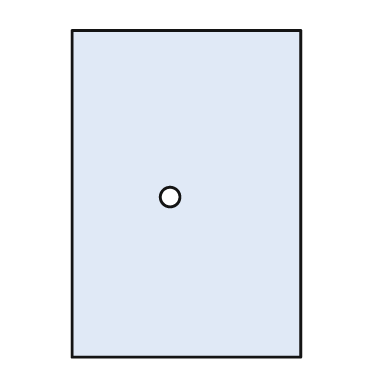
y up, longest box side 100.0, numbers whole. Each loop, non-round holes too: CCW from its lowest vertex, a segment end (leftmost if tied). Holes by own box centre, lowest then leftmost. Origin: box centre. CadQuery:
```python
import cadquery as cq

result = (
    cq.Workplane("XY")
    .moveTo(-35.0, -50.0)
    .lineTo(35.0, -50.0)
    .lineTo(35.0, 50.0)
    .lineTo(-35.0, 50.0)
    .close()
    .moveTo(-5.0, -1.0)
    .circle(3.0)
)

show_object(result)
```